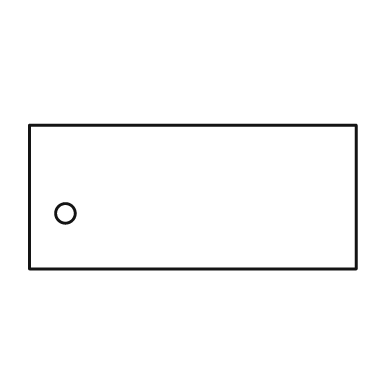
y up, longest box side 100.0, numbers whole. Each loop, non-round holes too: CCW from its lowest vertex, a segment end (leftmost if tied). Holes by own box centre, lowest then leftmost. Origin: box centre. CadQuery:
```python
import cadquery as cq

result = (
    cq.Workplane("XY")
    .moveTo(-50.0, -22.0)
    .lineTo(50.0, -22.0)
    .lineTo(50.0, 22.0)
    .lineTo(-50.0, 22.0)
    .close()
    .moveTo(-39.0, -5.0)
    .circle(3.0)
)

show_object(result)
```